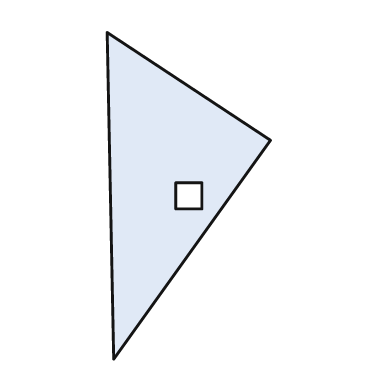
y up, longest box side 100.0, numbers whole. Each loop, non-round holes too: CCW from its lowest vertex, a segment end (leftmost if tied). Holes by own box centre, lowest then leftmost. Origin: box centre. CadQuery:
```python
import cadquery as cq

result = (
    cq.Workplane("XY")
    .moveTo(-23.0, -50.0)
    .lineTo(25.0, 17.0)
    .lineTo(-25.0, 50.0)
    .close()
    .moveTo(-4.0, -4.0)
    .lineTo(4.0, -4.0)
    .lineTo(4.0, 4.0)
    .lineTo(-4.0, 4.0)
    .close()
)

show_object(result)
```